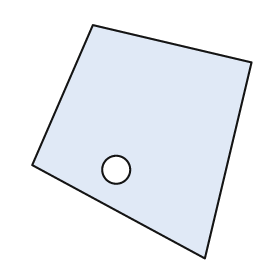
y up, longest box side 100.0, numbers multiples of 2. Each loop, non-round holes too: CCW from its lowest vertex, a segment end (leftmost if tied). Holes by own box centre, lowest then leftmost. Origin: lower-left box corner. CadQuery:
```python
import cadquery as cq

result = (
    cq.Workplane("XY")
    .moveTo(74.0, 0.0)
    .lineTo(94.0, 84.0)
    .lineTo(26.0, 100.0)
    .lineTo(0.0, 40.0)
    .close()
    .moveTo(36.0, 38.0)
    .circle(6.0)
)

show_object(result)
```